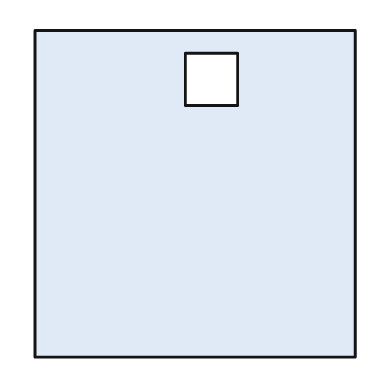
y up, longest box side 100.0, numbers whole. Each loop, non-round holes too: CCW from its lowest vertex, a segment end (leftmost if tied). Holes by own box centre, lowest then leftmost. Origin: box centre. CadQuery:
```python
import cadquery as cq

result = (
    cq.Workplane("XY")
    .moveTo(-49.0, -50.0)
    .lineTo(49.0, -50.0)
    .lineTo(49.0, 50.0)
    .lineTo(-49.0, 50.0)
    .close()
    .moveTo(-3.0, 27.0)
    .lineTo(13.0, 27.0)
    .lineTo(13.0, 43.0)
    .lineTo(-3.0, 43.0)
    .close()
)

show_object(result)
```